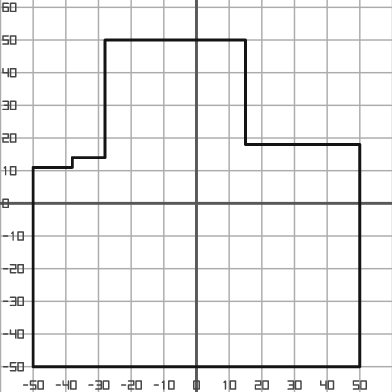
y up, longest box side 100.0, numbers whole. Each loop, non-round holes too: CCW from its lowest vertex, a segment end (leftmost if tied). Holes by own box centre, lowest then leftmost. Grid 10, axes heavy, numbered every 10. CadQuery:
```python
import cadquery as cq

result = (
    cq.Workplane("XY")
    .moveTo(-50.0, -50.0)
    .lineTo(50.0, -50.0)
    .lineTo(50.0, 18.0)
    .lineTo(15.0, 18.0)
    .lineTo(15.0, 50.0)
    .lineTo(-28.0, 50.0)
    .lineTo(-28.0, 14.0)
    .lineTo(-38.0, 14.0)
    .lineTo(-38.0, 11.0)
    .lineTo(-50.0, 11.0)
    .close()
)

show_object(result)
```